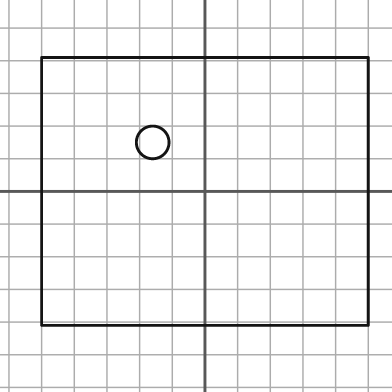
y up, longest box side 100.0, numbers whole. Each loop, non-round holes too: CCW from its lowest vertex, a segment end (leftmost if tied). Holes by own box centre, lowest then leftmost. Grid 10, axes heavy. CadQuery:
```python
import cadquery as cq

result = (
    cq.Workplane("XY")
    .moveTo(-50.0, -41.0)
    .lineTo(50.0, -41.0)
    .lineTo(50.0, 41.0)
    .lineTo(-50.0, 41.0)
    .close()
    .moveTo(-16.0, 15.0)
    .circle(5.0)
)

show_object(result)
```